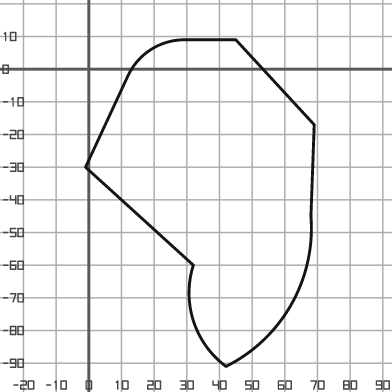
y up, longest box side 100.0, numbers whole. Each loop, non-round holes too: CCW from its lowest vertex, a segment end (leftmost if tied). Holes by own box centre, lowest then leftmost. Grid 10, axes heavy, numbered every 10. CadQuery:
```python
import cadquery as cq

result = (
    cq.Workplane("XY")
    .moveTo(42.0, -91.0)
    .threePointArc((62.0, -72.0), (68.0, -45.0))
    .lineTo(69.0, -17.0)
    .lineTo(45.0, 9.0)
    .lineTo(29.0, 9.0)
    .threePointArc((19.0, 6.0), (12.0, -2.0))
    .lineTo(-1.0, -30.0)
    .lineTo(32.0, -60.0)
    .threePointArc((32.0, -77.0), (42.0, -91.0))
    .close()
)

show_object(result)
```